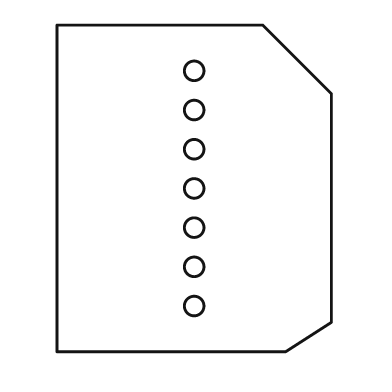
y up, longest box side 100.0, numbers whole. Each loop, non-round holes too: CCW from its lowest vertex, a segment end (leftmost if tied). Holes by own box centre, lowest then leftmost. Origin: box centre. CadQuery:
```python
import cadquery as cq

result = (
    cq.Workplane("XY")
    .moveTo(-42.0, -50.0)
    .lineTo(28.0, -50.0)
    .lineTo(42.0, -41.0)
    .lineTo(42.0, 29.0)
    .lineTo(21.0, 50.0)
    .lineTo(-42.0, 50.0)
    .close()
    .moveTo(0.0, -36.0)
    .circle(3.0)
    .moveTo(0.0, -24.0)
    .circle(3.0)
    .moveTo(0.0, -12.0)
    .circle(3.0)
    .moveTo(0.0, 0.0)
    .circle(3.0)
    .moveTo(0.0, 12.0)
    .circle(3.0)
    .moveTo(0.0, 24.0)
    .circle(3.0)
    .moveTo(0.0, 36.0)
    .circle(3.0)
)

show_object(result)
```